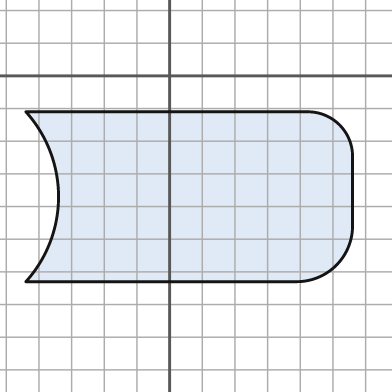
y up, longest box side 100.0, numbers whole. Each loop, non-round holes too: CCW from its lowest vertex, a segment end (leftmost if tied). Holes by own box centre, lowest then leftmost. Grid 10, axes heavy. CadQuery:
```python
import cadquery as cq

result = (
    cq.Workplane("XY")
    .moveTo(-44.0, -63.0)
    .lineTo(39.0, -63.0)
    .threePointArc((51.0, -58.0), (56.0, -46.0))
    .lineTo(56.0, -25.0)
    .threePointArc((52.0, -15.0), (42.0, -11.0))
    .lineTo(-44.0, -11.0)
    .threePointArc((-34.0, -37.0), (-44.0, -63.0))
    .close()
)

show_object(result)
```